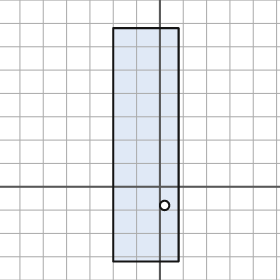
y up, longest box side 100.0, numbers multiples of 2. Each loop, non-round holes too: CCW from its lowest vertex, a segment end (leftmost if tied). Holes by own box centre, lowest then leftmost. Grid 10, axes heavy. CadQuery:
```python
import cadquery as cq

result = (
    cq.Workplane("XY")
    .moveTo(-20.0, -32.0)
    .lineTo(8.0, -32.0)
    .lineTo(8.0, 68.0)
    .lineTo(-20.0, 68.0)
    .close()
    .moveTo(2.0, -8.0)
    .circle(2.0)
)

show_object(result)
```